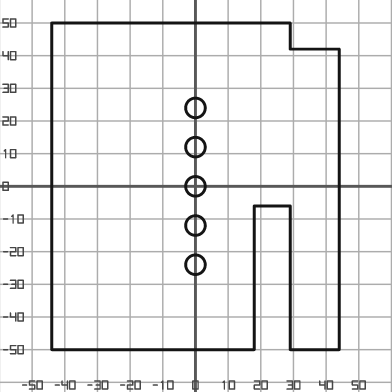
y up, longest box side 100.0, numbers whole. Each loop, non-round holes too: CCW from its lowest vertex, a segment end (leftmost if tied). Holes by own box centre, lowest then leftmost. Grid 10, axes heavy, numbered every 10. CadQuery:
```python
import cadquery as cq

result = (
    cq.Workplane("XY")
    .moveTo(-44.0, -50.0)
    .lineTo(18.0, -50.0)
    .lineTo(18.0, -6.0)
    .lineTo(29.0, -6.0)
    .lineTo(29.0, -50.0)
    .lineTo(44.0, -50.0)
    .lineTo(44.0, 42.0)
    .lineTo(29.0, 42.0)
    .lineTo(29.0, 50.0)
    .lineTo(-44.0, 50.0)
    .close()
    .moveTo(0.0, -24.0)
    .circle(3.0)
    .moveTo(0.0, -12.0)
    .circle(3.0)
    .moveTo(0.0, 0.0)
    .circle(3.0)
    .moveTo(0.0, 12.0)
    .circle(3.0)
    .moveTo(0.0, 24.0)
    .circle(3.0)
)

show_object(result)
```